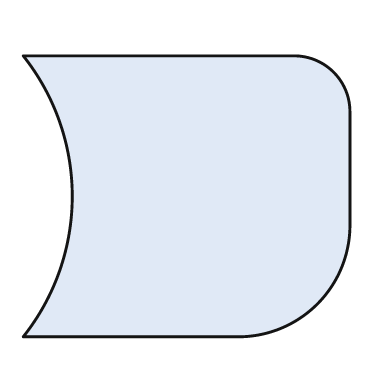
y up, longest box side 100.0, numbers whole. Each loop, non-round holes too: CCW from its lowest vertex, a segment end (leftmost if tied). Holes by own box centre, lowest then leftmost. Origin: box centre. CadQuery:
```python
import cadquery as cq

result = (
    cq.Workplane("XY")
    .moveTo(-50.0, -43.0)
    .lineTo(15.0, -43.0)
    .threePointArc((40.0, -33.0), (50.0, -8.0))
    .lineTo(50.0, 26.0)
    .threePointArc((45.0, 38.0), (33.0, 43.0))
    .lineTo(-50.0, 43.0)
    .threePointArc((-35.0, 0.0), (-50.0, -43.0))
    .close()
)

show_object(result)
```